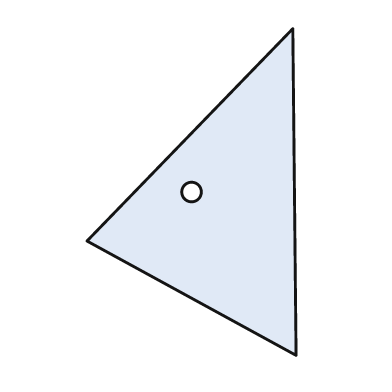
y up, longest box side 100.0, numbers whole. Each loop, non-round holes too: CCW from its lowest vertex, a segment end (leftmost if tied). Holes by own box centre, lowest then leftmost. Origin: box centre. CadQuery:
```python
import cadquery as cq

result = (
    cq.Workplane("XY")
    .moveTo(32.0, -50.0)
    .lineTo(31.0, 50.0)
    .lineTo(-32.0, -15.0)
    .close()
    .moveTo(0.0, 0.0)
    .circle(3.0)
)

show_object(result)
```